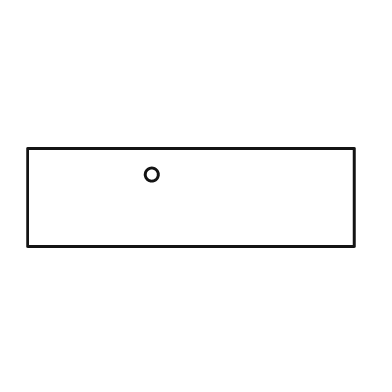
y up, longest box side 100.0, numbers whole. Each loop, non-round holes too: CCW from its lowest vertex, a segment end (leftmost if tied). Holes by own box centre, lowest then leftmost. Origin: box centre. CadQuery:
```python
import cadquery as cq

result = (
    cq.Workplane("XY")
    .moveTo(-50.0, -15.0)
    .lineTo(50.0, -15.0)
    .lineTo(50.0, 15.0)
    .lineTo(-50.0, 15.0)
    .close()
    .moveTo(-12.0, 7.0)
    .circle(2.0)
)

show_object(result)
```